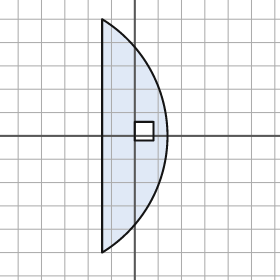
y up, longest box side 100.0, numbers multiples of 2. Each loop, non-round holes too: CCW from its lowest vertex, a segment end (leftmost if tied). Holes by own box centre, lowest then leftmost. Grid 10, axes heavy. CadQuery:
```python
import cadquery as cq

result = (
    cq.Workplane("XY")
    .moveTo(-14.0, -50.0)
    .threePointArc((14.0, 0.0), (-14.0, 50.0))
    .close()
    .moveTo(0.0, -2.0)
    .lineTo(8.0, -2.0)
    .lineTo(8.0, 6.0)
    .lineTo(0.0, 6.0)
    .close()
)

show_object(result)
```